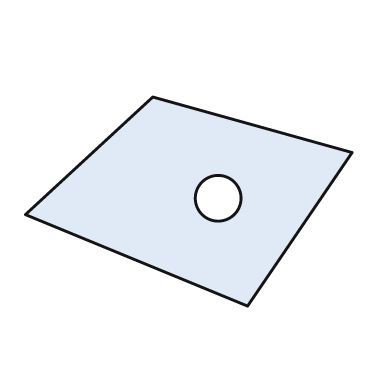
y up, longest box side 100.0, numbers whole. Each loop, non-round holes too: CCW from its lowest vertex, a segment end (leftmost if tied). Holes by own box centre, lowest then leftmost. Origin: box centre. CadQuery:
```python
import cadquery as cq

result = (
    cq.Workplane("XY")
    .moveTo(18.0, -32.0)
    .lineTo(50.0, 15.0)
    .lineTo(-11.0, 32.0)
    .lineTo(-50.0, -4.0)
    .close()
    .moveTo(9.0, 1.0)
    .circle(7.0)
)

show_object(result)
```